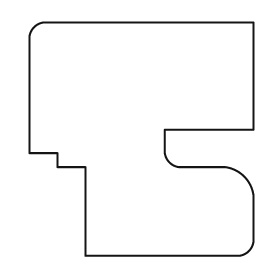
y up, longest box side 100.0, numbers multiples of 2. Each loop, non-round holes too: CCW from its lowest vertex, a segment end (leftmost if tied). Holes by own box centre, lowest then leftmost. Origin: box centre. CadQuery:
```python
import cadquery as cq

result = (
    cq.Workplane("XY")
    .moveTo(-24.0, -50.0)
    .lineTo(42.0, -50.0)
    .threePointArc((46.0, -48.0), (48.0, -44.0))
    .lineTo(48.0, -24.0)
    .threePointArc((44.0, -16.0), (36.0, -12.0))
    .lineTo(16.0, -12.0)
    .threePointArc((12.0, -10.0), (10.0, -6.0))
    .lineTo(10.0, 4.0)
    .lineTo(48.0, 4.0)
    .lineTo(48.0, 50.0)
    .lineTo(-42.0, 50.0)
    .threePointArc((-46.0, 48.0), (-48.0, 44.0))
    .lineTo(-48.0, -6.0)
    .lineTo(-36.0, -6.0)
    .lineTo(-36.0, -12.0)
    .lineTo(-24.0, -12.0)
    .close()
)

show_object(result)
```